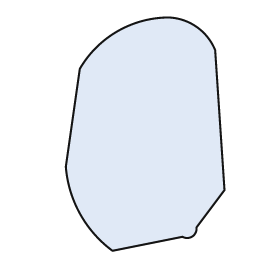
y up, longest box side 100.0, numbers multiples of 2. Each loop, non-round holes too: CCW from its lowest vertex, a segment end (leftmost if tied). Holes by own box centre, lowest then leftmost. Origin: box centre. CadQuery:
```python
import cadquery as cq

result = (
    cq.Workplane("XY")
    .moveTo(-14.0, -50.0)
    .lineTo(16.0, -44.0)
    .threePointArc((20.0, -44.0), (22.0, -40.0))
    .lineTo(34.0, -24.0)
    .lineTo(30.0, 36.0)
    .threePointArc((22.0, 46.0), (10.0, 50.0))
    .threePointArc((-12.0, 44.0), (-28.0, 28.0))
    .lineTo(-34.0, -14.0)
    .threePointArc((-28.0, -34.0), (-14.0, -50.0))
    .close()
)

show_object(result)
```